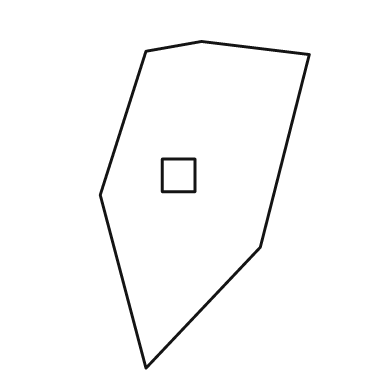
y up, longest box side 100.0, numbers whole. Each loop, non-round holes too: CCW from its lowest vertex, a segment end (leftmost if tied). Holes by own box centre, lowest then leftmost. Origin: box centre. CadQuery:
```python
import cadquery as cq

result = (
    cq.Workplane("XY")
    .moveTo(-18.0, -50.0)
    .lineTo(17.0, -13.0)
    .lineTo(32.0, 46.0)
    .lineTo(-1.0, 50.0)
    .lineTo(-18.0, 47.0)
    .lineTo(-32.0, 3.0)
    .close()
    .moveTo(-13.0, 4.0)
    .lineTo(-3.0, 4.0)
    .lineTo(-3.0, 14.0)
    .lineTo(-13.0, 14.0)
    .close()
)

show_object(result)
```